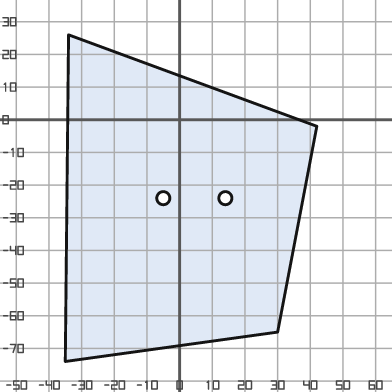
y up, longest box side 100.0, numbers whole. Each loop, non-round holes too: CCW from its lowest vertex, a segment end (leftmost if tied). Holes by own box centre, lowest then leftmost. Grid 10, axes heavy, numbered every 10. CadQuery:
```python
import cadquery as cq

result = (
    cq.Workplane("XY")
    .moveTo(-35.0, -74.0)
    .lineTo(30.0, -65.0)
    .lineTo(42.0, -2.0)
    .lineTo(-34.0, 26.0)
    .close()
    .moveTo(-5.0, -24.0)
    .circle(2.0)
    .moveTo(14.0, -24.0)
    .circle(2.0)
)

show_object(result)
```